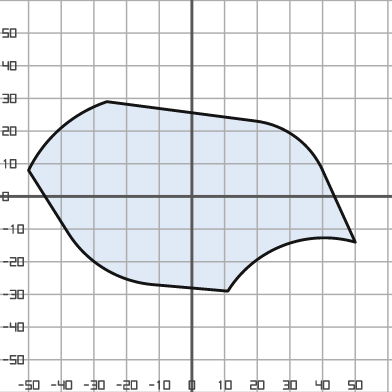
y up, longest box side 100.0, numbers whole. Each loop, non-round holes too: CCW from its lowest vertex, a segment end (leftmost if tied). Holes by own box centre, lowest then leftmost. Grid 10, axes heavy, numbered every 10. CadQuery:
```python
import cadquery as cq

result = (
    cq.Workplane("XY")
    .moveTo(11.0, -29.0)
    .threePointArc((28.0, -15.0), (50.0, -14.0))
    .lineTo(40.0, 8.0)
    .threePointArc((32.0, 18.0), (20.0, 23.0))
    .lineTo(-26.0, 29.0)
    .threePointArc((-40.0, 21.0), (-50.0, 8.0))
    .lineTo(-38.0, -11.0)
    .threePointArc((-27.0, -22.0), (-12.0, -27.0))
    .close()
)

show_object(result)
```